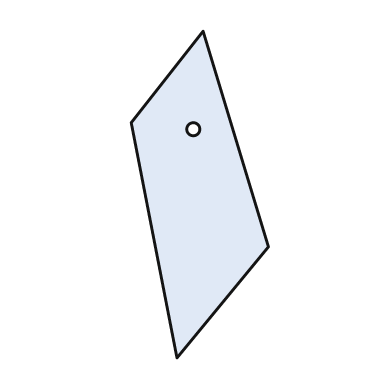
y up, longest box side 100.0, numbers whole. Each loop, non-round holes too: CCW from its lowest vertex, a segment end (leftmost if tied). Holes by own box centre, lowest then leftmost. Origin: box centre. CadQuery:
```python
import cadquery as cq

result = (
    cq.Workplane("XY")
    .moveTo(-7.0, -50.0)
    .lineTo(21.0, -16.0)
    .lineTo(1.0, 50.0)
    .lineTo(-21.0, 22.0)
    .close()
    .moveTo(-2.0, 20.0)
    .circle(2.0)
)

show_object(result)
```